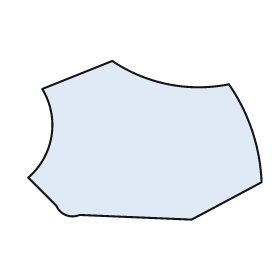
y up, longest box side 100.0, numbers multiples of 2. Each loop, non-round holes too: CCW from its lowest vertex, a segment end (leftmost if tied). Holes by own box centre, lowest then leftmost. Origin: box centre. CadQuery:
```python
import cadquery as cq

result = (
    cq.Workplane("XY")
    .moveTo(20.0, -34.0)
    .lineTo(50.0, -18.0)
    .threePointArc((46.0, 4.0), (36.0, 24.0))
    .threePointArc((10.0, 24.0), (-14.0, 34.0))
    .lineTo(-44.0, 22.0)
    .threePointArc((-40.0, 2.0), (-50.0, -16.0))
    .lineTo(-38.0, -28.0)
    .threePointArc((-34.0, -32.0), (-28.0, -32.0))
    .close()
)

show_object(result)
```